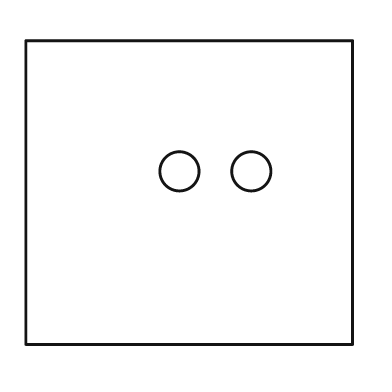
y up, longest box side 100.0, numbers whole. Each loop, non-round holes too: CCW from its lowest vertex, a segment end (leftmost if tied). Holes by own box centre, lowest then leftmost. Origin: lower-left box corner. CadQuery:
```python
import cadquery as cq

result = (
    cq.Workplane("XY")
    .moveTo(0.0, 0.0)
    .lineTo(100.0, 0.0)
    .lineTo(100.0, 93.0)
    .lineTo(0.0, 93.0)
    .close()
    .moveTo(47.0, 53.0)
    .circle(6.0)
    .moveTo(69.0, 53.0)
    .circle(6.0)
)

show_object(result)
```